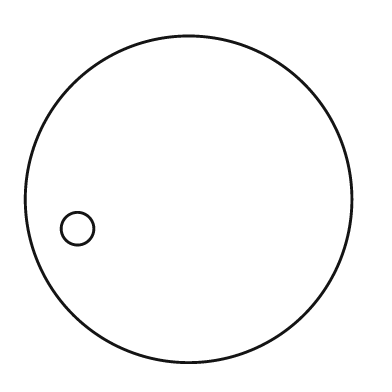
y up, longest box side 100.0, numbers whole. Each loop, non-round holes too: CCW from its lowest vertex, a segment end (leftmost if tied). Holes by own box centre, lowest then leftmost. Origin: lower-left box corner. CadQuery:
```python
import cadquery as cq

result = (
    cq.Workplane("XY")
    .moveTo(50.0, 50.0)
    .circle(50.0)
    .moveTo(16.0, 41.0)
    .circle(5.0)
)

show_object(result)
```